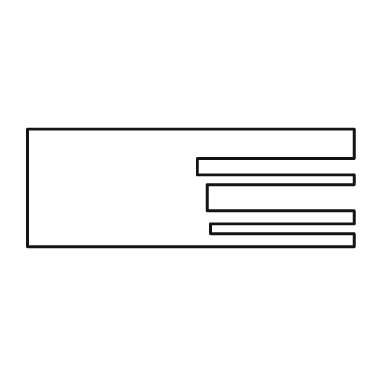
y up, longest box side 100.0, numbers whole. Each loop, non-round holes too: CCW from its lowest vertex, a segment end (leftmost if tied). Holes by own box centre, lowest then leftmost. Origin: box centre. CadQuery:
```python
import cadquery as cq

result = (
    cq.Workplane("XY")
    .moveTo(-50.0, -18.0)
    .lineTo(50.0, -18.0)
    .lineTo(50.0, -14.0)
    .lineTo(6.0, -14.0)
    .lineTo(6.0, -11.0)
    .lineTo(50.0, -11.0)
    .lineTo(50.0, -7.0)
    .lineTo(5.0, -7.0)
    .lineTo(5.0, 1.0)
    .lineTo(50.0, 1.0)
    .lineTo(50.0, 4.0)
    .lineTo(2.0, 4.0)
    .lineTo(2.0, 9.0)
    .lineTo(50.0, 9.0)
    .lineTo(50.0, 18.0)
    .lineTo(-50.0, 18.0)
    .close()
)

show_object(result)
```